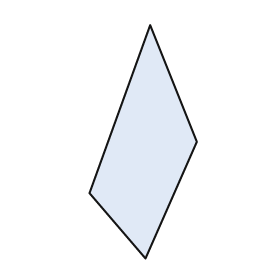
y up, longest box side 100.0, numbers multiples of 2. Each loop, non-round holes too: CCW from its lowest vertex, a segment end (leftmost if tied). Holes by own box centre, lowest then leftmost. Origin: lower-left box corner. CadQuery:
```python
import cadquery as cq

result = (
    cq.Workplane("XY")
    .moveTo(24.0, 0.0)
    .lineTo(46.0, 50.0)
    .lineTo(26.0, 100.0)
    .lineTo(0.0, 28.0)
    .close()
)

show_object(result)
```